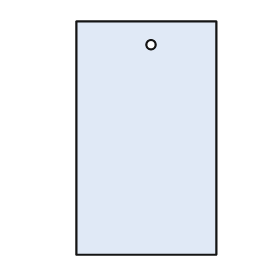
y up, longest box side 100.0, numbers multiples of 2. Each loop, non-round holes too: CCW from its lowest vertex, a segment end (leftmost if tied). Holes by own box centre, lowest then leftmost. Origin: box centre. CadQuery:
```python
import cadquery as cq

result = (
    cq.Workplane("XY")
    .moveTo(-30.0, -50.0)
    .lineTo(30.0, -50.0)
    .lineTo(30.0, 50.0)
    .lineTo(-30.0, 50.0)
    .close()
    .moveTo(2.0, 40.0)
    .circle(2.0)
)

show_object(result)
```